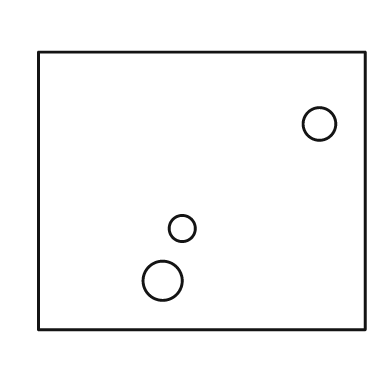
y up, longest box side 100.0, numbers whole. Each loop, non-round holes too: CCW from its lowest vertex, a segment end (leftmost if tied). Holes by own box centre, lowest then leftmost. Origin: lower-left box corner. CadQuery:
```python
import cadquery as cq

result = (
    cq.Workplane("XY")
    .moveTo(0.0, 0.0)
    .lineTo(100.0, 0.0)
    .lineTo(100.0, 85.0)
    .lineTo(0.0, 85.0)
    .close()
    .moveTo(38.0, 15.0)
    .circle(6.0)
    .moveTo(44.0, 31.0)
    .circle(4.0)
    .moveTo(86.0, 63.0)
    .circle(5.0)
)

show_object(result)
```